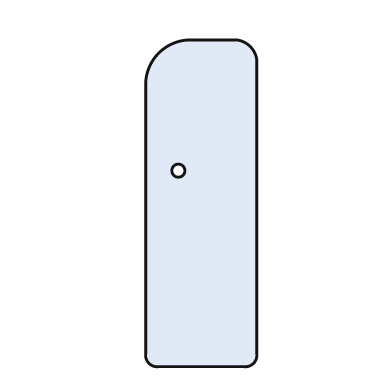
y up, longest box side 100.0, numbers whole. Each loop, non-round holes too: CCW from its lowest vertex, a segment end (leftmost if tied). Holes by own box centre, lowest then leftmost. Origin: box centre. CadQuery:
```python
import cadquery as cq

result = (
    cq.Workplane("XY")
    .moveTo(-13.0, -50.0)
    .lineTo(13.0, -50.0)
    .threePointArc((16.0, -49.0), (17.0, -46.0))
    .lineTo(17.0, 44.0)
    .threePointArc((15.0, 48.0), (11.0, 50.0))
    .lineTo(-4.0, 50.0)
    .threePointArc((-13.0, 46.0), (-17.0, 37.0))
    .lineTo(-17.0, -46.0)
    .threePointArc((-16.0, -49.0), (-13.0, -50.0))
    .close()
    .moveTo(-7.0, 10.0)
    .circle(2.0)
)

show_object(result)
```